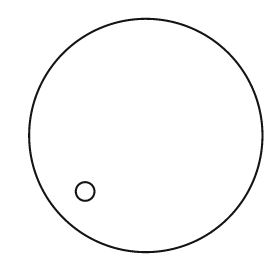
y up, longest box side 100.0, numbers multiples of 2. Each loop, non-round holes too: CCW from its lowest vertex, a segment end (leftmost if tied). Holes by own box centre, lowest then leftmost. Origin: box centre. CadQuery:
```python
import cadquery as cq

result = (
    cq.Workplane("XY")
    .moveTo(0.0, 0.0)
    .circle(50.0)
    .moveTo(-26.0, -24.0)
    .circle(4.0)
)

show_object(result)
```